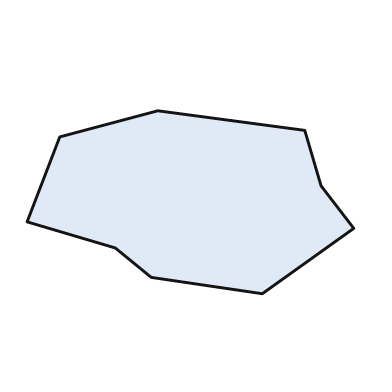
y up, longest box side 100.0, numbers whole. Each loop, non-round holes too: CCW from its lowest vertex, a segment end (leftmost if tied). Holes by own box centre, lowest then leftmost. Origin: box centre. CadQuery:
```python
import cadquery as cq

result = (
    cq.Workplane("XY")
    .moveTo(22.0, -28.0)
    .lineTo(50.0, -8.0)
    .lineTo(40.0, 5.0)
    .lineTo(35.0, 22.0)
    .lineTo(-10.0, 28.0)
    .lineTo(-40.0, 20.0)
    .lineTo(-50.0, -6.0)
    .lineTo(-23.0, -14.0)
    .lineTo(-12.0, -23.0)
    .close()
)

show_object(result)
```